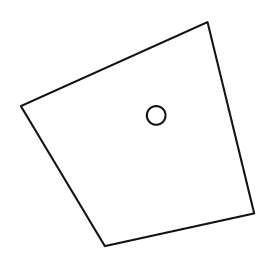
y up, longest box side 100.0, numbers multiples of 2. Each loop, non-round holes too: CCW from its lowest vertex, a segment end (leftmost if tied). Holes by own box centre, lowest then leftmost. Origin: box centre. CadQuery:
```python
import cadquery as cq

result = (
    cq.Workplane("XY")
    .moveTo(-14.0, -48.0)
    .lineTo(50.0, -34.0)
    .lineTo(30.0, 48.0)
    .lineTo(-50.0, 12.0)
    .close()
    .moveTo(8.0, 8.0)
    .circle(4.0)
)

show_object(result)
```